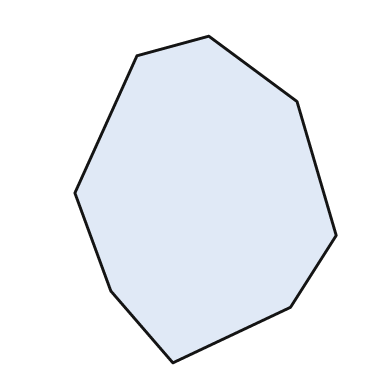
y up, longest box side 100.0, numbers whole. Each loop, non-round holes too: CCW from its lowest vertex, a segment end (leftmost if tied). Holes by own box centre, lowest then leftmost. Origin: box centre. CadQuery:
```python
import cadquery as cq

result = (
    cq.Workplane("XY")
    .moveTo(-10.0, -50.0)
    .lineTo(26.0, -33.0)
    .lineTo(40.0, -11.0)
    .lineTo(28.0, 30.0)
    .lineTo(1.0, 50.0)
    .lineTo(-21.0, 44.0)
    .lineTo(-40.0, 2.0)
    .lineTo(-29.0, -28.0)
    .close()
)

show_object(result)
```